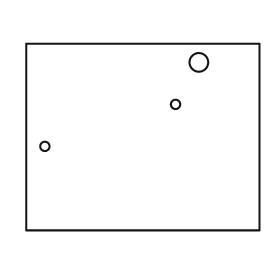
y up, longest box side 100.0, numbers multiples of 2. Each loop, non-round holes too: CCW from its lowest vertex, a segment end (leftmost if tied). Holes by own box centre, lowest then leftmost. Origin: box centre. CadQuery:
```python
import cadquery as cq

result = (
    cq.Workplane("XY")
    .moveTo(-50.0, -40.0)
    .lineTo(50.0, -40.0)
    .lineTo(50.0, 40.0)
    .lineTo(-50.0, 40.0)
    .close()
    .moveTo(-42.0, -4.0)
    .circle(2.0)
    .moveTo(14.0, 14.0)
    .circle(2.0)
    .moveTo(24.0, 32.0)
    .circle(4.0)
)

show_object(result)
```